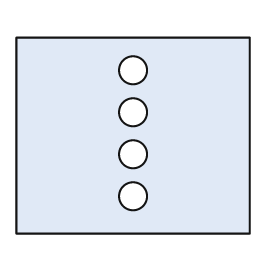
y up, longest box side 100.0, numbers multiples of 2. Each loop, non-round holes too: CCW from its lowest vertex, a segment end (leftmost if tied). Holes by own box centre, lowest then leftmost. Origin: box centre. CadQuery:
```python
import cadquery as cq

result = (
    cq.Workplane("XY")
    .moveTo(-50.0, -42.0)
    .lineTo(50.0, -42.0)
    .lineTo(50.0, 42.0)
    .lineTo(-50.0, 42.0)
    .close()
    .moveTo(0.0, -26.0)
    .circle(6.0)
    .moveTo(0.0, -8.0)
    .circle(6.0)
    .moveTo(0.0, 10.0)
    .circle(6.0)
    .moveTo(0.0, 28.0)
    .circle(6.0)
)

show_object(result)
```